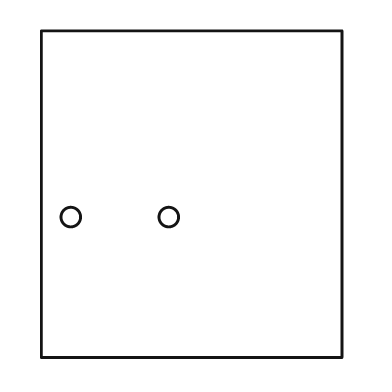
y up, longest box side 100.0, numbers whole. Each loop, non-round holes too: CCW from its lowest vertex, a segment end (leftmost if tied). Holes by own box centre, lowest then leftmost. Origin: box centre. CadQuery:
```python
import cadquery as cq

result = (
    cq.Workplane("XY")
    .moveTo(-46.0, -50.0)
    .lineTo(46.0, -50.0)
    .lineTo(46.0, 50.0)
    .lineTo(-46.0, 50.0)
    .close()
    .moveTo(-37.0, -7.0)
    .circle(3.0)
    .moveTo(-7.0, -7.0)
    .circle(3.0)
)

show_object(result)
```